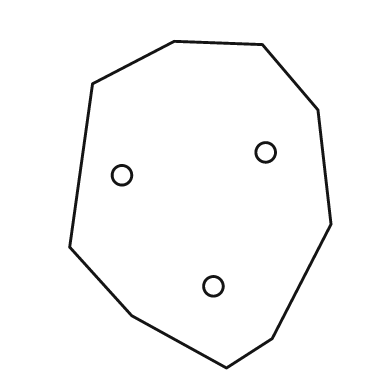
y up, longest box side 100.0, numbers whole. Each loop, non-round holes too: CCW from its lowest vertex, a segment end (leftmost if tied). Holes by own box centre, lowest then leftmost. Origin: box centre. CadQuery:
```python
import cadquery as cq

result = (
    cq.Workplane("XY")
    .moveTo(8.0, -50.0)
    .lineTo(22.0, -41.0)
    .lineTo(40.0, -6.0)
    .lineTo(36.0, 29.0)
    .lineTo(19.0, 49.0)
    .lineTo(-8.0, 50.0)
    .lineTo(-33.0, 37.0)
    .lineTo(-40.0, -13.0)
    .lineTo(-21.0, -34.0)
    .close()
    .moveTo(4.0, -25.0)
    .circle(3.0)
    .moveTo(-24.0, 9.0)
    .circle(3.0)
    .moveTo(20.0, 16.0)
    .circle(3.0)
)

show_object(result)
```